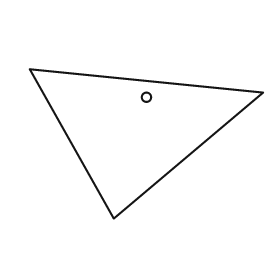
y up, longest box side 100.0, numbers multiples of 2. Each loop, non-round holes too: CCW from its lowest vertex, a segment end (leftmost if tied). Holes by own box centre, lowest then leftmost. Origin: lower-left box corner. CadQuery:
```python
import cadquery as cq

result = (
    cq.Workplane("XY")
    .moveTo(36.0, 0.0)
    .lineTo(100.0, 54.0)
    .lineTo(0.0, 64.0)
    .close()
    .moveTo(50.0, 52.0)
    .circle(2.0)
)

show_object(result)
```